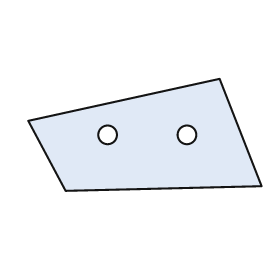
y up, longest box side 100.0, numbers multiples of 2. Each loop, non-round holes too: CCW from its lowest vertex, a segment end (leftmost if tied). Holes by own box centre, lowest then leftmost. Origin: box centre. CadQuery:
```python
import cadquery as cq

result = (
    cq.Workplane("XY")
    .moveTo(-34.0, -24.0)
    .lineTo(50.0, -22.0)
    .lineTo(32.0, 24.0)
    .lineTo(-50.0, 6.0)
    .close()
    .moveTo(-16.0, 0.0)
    .circle(4.0)
    .moveTo(18.0, 0.0)
    .circle(4.0)
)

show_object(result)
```